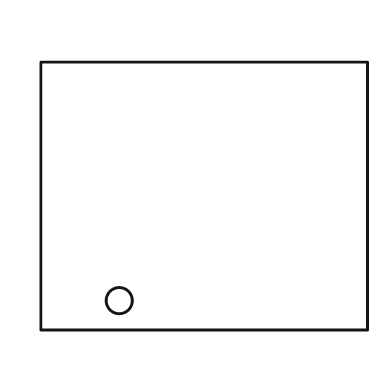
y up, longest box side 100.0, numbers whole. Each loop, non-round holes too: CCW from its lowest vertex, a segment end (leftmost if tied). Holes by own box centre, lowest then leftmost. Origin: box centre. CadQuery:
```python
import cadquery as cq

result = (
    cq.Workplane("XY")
    .moveTo(-50.0, -41.0)
    .lineTo(50.0, -41.0)
    .lineTo(50.0, 41.0)
    .lineTo(-50.0, 41.0)
    .close()
    .moveTo(-26.0, -32.0)
    .circle(4.0)
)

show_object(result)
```